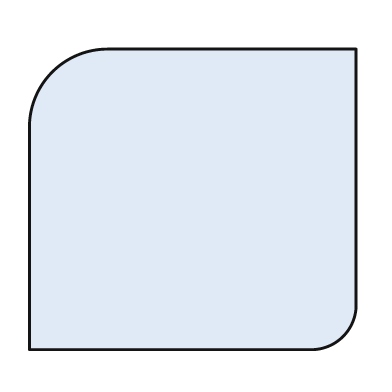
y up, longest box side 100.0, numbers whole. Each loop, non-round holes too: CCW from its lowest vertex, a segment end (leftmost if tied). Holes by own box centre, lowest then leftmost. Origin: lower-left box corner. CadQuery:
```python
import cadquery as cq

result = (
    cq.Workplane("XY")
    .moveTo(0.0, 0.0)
    .lineTo(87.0, 0.0)
    .threePointArc((96.0, 4.0), (100.0, 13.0))
    .lineTo(100.0, 92.0)
    .lineTo(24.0, 92.0)
    .threePointArc((7.0, 85.0), (0.0, 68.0))
    .close()
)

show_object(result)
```